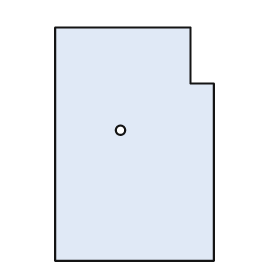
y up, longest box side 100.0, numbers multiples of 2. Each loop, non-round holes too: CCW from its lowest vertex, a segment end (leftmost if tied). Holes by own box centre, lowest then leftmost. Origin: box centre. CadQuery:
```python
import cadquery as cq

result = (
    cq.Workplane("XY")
    .moveTo(-34.0, -50.0)
    .lineTo(34.0, -50.0)
    .lineTo(34.0, 26.0)
    .lineTo(24.0, 26.0)
    .lineTo(24.0, 50.0)
    .lineTo(-34.0, 50.0)
    .close()
    .moveTo(-6.0, 6.0)
    .circle(2.0)
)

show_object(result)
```